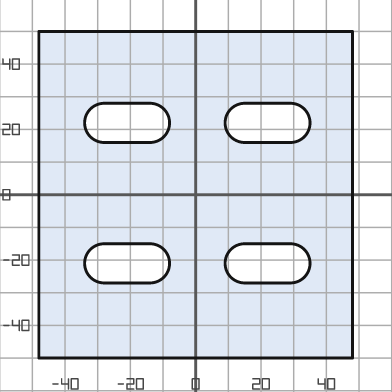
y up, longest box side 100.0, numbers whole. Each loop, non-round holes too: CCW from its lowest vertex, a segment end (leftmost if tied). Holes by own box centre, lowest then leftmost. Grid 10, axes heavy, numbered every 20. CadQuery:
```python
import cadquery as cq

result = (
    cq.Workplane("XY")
    .moveTo(-48.0, -50.0)
    .lineTo(48.0, -50.0)
    .lineTo(48.0, 50.0)
    .lineTo(-48.0, 50.0)
    .close()
    .moveTo(-28.0, -27.0)
    .lineTo(-14.0, -27.0)
    .threePointArc((-8.0, -21.0), (-14.0, -15.0))
    .lineTo(-28.0, -15.0)
    .threePointArc((-34.0, -21.0), (-28.0, -27.0))
    .close()
    .moveTo(15.0, -27.0)
    .lineTo(29.0, -27.0)
    .threePointArc((35.0, -21.0), (29.0, -15.0))
    .lineTo(15.0, -15.0)
    .threePointArc((9.0, -21.0), (15.0, -27.0))
    .close()
    .moveTo(-28.0, 16.0)
    .lineTo(-14.0, 16.0)
    .threePointArc((-8.0, 22.0), (-14.0, 28.0))
    .lineTo(-28.0, 28.0)
    .threePointArc((-34.0, 22.0), (-28.0, 16.0))
    .close()
    .moveTo(15.0, 16.0)
    .lineTo(29.0, 16.0)
    .threePointArc((35.0, 22.0), (29.0, 28.0))
    .lineTo(15.0, 28.0)
    .threePointArc((9.0, 22.0), (15.0, 16.0))
    .close()
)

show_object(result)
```